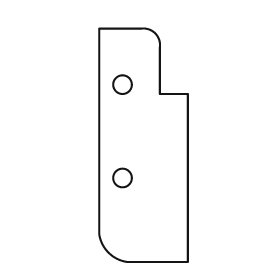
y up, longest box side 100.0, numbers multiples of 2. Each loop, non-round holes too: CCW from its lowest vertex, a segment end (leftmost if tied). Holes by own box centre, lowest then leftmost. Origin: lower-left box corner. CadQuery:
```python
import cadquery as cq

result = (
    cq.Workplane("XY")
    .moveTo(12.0, 0.0)
    .lineTo(38.0, 0.0)
    .lineTo(38.0, 72.0)
    .lineTo(26.0, 72.0)
    .lineTo(26.0, 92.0)
    .threePointArc((24.0, 98.0), (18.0, 100.0))
    .lineTo(0.0, 100.0)
    .lineTo(0.0, 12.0)
    .threePointArc((4.0, 4.0), (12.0, 0.0))
    .close()
    .moveTo(10.0, 36.0)
    .circle(4.0)
    .moveTo(10.0, 76.0)
    .circle(4.0)
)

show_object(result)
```